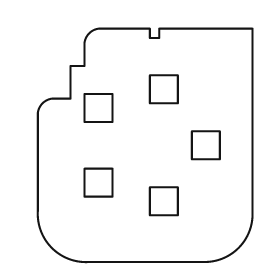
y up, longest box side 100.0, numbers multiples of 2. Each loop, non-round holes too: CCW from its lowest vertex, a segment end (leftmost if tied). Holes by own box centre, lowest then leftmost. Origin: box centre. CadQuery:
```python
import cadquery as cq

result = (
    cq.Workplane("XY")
    .moveTo(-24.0, -50.0)
    .lineTo(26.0, -50.0)
    .threePointArc((40.0, -44.0), (46.0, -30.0))
    .lineTo(46.0, 50.0)
    .lineTo(6.0, 50.0)
    .lineTo(6.0, 46.0)
    .lineTo(2.0, 46.0)
    .lineTo(2.0, 50.0)
    .lineTo(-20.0, 50.0)
    .threePointArc((-24.0, 48.0), (-26.0, 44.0))
    .lineTo(-26.0, 34.0)
    .lineTo(-32.0, 34.0)
    .lineTo(-32.0, 20.0)
    .lineTo(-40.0, 20.0)
    .threePointArc((-44.0, 18.0), (-46.0, 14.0))
    .lineTo(-46.0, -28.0)
    .threePointArc((-40.0, -44.0), (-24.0, -50.0))
    .close()
    .moveTo(2.0, -30.0)
    .lineTo(14.0, -30.0)
    .lineTo(14.0, -18.0)
    .lineTo(2.0, -18.0)
    .close()
    .moveTo(-26.0, -22.0)
    .lineTo(-14.0, -22.0)
    .lineTo(-14.0, -10.0)
    .lineTo(-26.0, -10.0)
    .close()
    .moveTo(20.0, -6.0)
    .lineTo(32.0, -6.0)
    .lineTo(32.0, 6.0)
    .lineTo(20.0, 6.0)
    .close()
    .moveTo(-26.0, 10.0)
    .lineTo(-14.0, 10.0)
    .lineTo(-14.0, 22.0)
    .lineTo(-26.0, 22.0)
    .close()
    .moveTo(2.0, 18.0)
    .lineTo(14.0, 18.0)
    .lineTo(14.0, 30.0)
    .lineTo(2.0, 30.0)
    .close()
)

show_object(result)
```